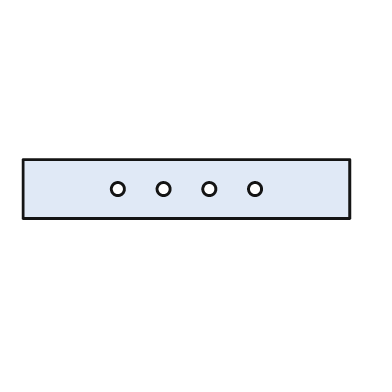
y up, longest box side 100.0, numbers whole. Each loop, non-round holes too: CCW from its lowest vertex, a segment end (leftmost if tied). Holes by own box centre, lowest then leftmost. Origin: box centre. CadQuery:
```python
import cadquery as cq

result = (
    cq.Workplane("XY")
    .moveTo(-50.0, -9.0)
    .lineTo(50.0, -9.0)
    .lineTo(50.0, 9.0)
    .lineTo(-50.0, 9.0)
    .close()
    .moveTo(-21.0, 0.0)
    .circle(2.0)
    .moveTo(-7.0, 0.0)
    .circle(2.0)
    .moveTo(7.0, 0.0)
    .circle(2.0)
    .moveTo(21.0, 0.0)
    .circle(2.0)
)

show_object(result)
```